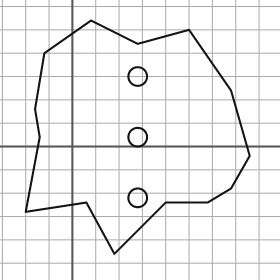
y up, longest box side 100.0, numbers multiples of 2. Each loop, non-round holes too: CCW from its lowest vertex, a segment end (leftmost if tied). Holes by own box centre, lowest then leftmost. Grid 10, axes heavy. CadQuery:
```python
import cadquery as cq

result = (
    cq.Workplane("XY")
    .moveTo(18.0, -46.0)
    .lineTo(40.0, -24.0)
    .lineTo(58.0, -24.0)
    .lineTo(68.0, -18.0)
    .lineTo(76.0, -4.0)
    .lineTo(68.0, 24.0)
    .lineTo(50.0, 50.0)
    .lineTo(28.0, 44.0)
    .lineTo(8.0, 54.0)
    .lineTo(-12.0, 40.0)
    .lineTo(-16.0, 16.0)
    .lineTo(-14.0, 4.0)
    .lineTo(-20.0, -28.0)
    .lineTo(6.0, -24.0)
    .close()
    .moveTo(28.0, -22.0)
    .circle(4.0)
    .moveTo(28.0, 4.0)
    .circle(4.0)
    .moveTo(28.0, 30.0)
    .circle(4.0)
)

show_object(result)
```